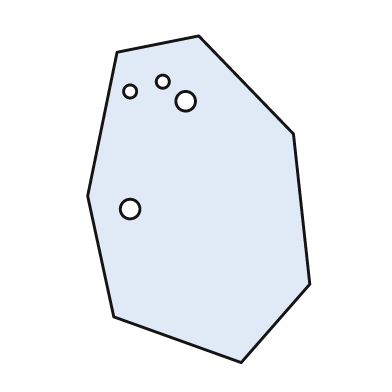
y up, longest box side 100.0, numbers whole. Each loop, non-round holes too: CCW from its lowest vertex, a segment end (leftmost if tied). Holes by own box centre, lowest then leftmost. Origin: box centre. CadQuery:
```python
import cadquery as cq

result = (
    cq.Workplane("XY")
    .moveTo(13.0, -50.0)
    .lineTo(34.0, -26.0)
    .lineTo(29.0, 20.0)
    .lineTo(0.0, 50.0)
    .lineTo(-25.0, 45.0)
    .lineTo(-34.0, 1.0)
    .lineTo(-26.0, -36.0)
    .close()
    .moveTo(-21.0, -3.0)
    .circle(3.0)
    .moveTo(-4.0, 30.0)
    .circle(3.0)
    .moveTo(-21.0, 33.0)
    .circle(2.0)
    .moveTo(-11.0, 36.0)
    .circle(2.0)
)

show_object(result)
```